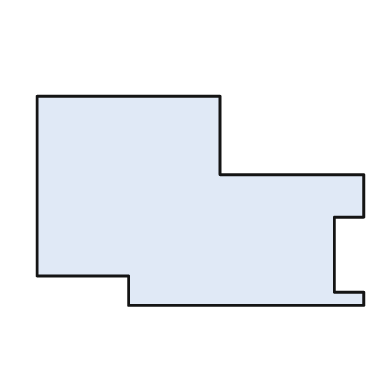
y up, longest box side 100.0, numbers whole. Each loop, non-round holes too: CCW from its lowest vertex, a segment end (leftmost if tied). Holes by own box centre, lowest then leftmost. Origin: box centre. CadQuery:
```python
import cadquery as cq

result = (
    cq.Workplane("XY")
    .moveTo(-22.0, -32.0)
    .lineTo(50.0, -32.0)
    .lineTo(50.0, -28.0)
    .lineTo(41.0, -28.0)
    .lineTo(41.0, -5.0)
    .lineTo(50.0, -5.0)
    .lineTo(50.0, 8.0)
    .lineTo(6.0, 8.0)
    .lineTo(6.0, 32.0)
    .lineTo(-50.0, 32.0)
    .lineTo(-50.0, -23.0)
    .lineTo(-22.0, -23.0)
    .close()
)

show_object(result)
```